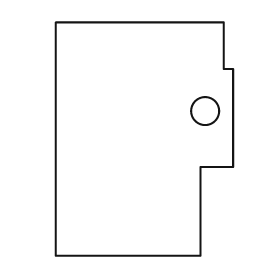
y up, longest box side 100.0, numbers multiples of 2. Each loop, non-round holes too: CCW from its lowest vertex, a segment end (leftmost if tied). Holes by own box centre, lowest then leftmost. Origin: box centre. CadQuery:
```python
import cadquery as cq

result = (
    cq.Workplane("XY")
    .moveTo(-38.0, -50.0)
    .lineTo(24.0, -50.0)
    .lineTo(24.0, -12.0)
    .lineTo(38.0, -12.0)
    .lineTo(38.0, 30.0)
    .lineTo(34.0, 30.0)
    .lineTo(34.0, 50.0)
    .lineTo(-38.0, 50.0)
    .close()
    .moveTo(26.0, 12.0)
    .circle(6.0)
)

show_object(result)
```